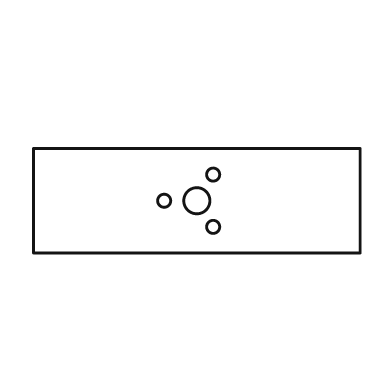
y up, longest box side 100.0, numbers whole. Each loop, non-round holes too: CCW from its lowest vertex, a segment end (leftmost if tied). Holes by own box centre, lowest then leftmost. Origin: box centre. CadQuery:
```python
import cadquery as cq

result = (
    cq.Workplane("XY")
    .moveTo(-50.0, -16.0)
    .lineTo(50.0, -16.0)
    .lineTo(50.0, 16.0)
    .lineTo(-50.0, 16.0)
    .close()
    .moveTo(5.0, -8.0)
    .circle(2.0)
    .moveTo(-10.0, 0.0)
    .circle(2.0)
    .moveTo(0.0, 0.0)
    .circle(4.0)
    .moveTo(5.0, 8.0)
    .circle(2.0)
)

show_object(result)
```